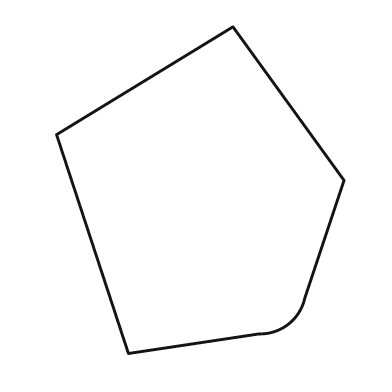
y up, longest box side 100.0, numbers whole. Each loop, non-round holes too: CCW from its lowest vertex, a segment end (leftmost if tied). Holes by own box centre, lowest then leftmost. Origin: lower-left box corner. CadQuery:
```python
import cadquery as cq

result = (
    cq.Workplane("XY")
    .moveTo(22.0, 0.0)
    .lineTo(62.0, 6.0)
    .threePointArc((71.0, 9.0), (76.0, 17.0))
    .lineTo(88.0, 53.0)
    .lineTo(54.0, 100.0)
    .lineTo(0.0, 67.0)
    .close()
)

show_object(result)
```